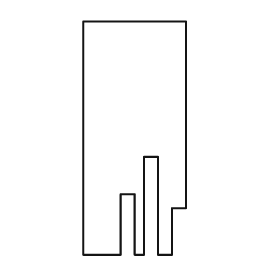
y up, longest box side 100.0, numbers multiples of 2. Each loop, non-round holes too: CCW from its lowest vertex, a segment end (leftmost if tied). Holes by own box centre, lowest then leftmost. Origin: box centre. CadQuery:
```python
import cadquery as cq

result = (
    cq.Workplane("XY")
    .moveTo(-22.0, -50.0)
    .lineTo(-6.0, -50.0)
    .lineTo(-6.0, -24.0)
    .lineTo(0.0, -24.0)
    .lineTo(0.0, -50.0)
    .lineTo(4.0, -50.0)
    .lineTo(4.0, -8.0)
    .lineTo(10.0, -8.0)
    .lineTo(10.0, -50.0)
    .lineTo(16.0, -50.0)
    .lineTo(16.0, -30.0)
    .lineTo(22.0, -30.0)
    .lineTo(22.0, 50.0)
    .lineTo(-22.0, 50.0)
    .close()
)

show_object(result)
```